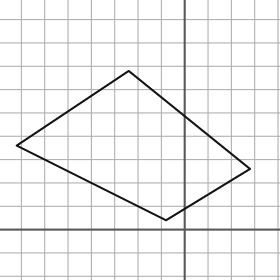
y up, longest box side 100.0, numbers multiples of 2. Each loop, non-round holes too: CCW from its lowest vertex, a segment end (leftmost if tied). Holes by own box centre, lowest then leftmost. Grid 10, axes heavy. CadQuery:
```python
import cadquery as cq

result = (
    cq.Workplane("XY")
    .moveTo(-8.0, 4.0)
    .lineTo(28.0, 26.0)
    .lineTo(-24.0, 68.0)
    .lineTo(-72.0, 36.0)
    .close()
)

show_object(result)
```